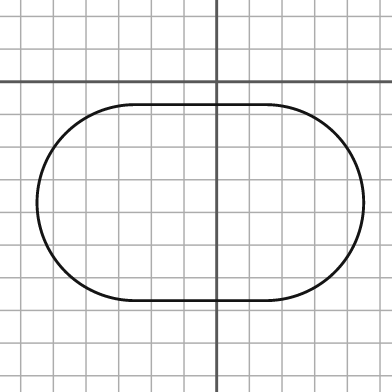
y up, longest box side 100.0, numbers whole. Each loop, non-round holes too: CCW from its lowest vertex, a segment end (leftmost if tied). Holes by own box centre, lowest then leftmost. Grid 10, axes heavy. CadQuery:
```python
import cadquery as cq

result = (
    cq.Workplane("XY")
    .moveTo(-25.0, -67.0)
    .lineTo(15.0, -67.0)
    .threePointArc((45.0, -37.0), (15.0, -7.0))
    .lineTo(-25.0, -7.0)
    .threePointArc((-55.0, -37.0), (-25.0, -67.0))
    .close()
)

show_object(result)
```